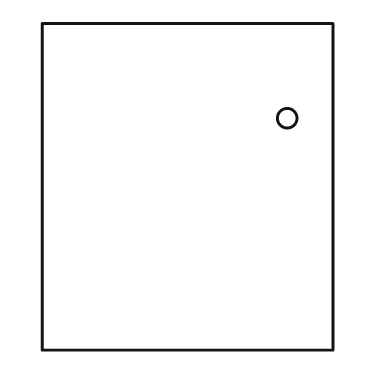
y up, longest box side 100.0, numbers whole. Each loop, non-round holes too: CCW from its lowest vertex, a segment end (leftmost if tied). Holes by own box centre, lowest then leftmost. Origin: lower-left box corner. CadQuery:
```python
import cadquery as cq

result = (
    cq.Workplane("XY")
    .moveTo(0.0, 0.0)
    .lineTo(89.0, 0.0)
    .lineTo(89.0, 100.0)
    .lineTo(0.0, 100.0)
    .close()
    .moveTo(75.0, 71.0)
    .circle(3.0)
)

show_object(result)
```